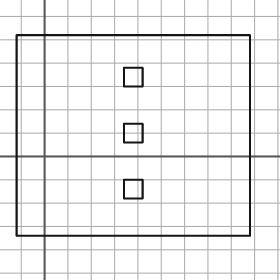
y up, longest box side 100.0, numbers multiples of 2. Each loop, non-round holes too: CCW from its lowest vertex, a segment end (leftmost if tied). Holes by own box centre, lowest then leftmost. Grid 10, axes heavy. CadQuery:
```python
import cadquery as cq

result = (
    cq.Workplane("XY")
    .moveTo(-12.0, -34.0)
    .lineTo(88.0, -34.0)
    .lineTo(88.0, 52.0)
    .lineTo(-12.0, 52.0)
    .close()
    .moveTo(34.0, -18.0)
    .lineTo(42.0, -18.0)
    .lineTo(42.0, -10.0)
    .lineTo(34.0, -10.0)
    .close()
    .moveTo(34.0, 6.0)
    .lineTo(42.0, 6.0)
    .lineTo(42.0, 14.0)
    .lineTo(34.0, 14.0)
    .close()
    .moveTo(34.0, 30.0)
    .lineTo(42.0, 30.0)
    .lineTo(42.0, 38.0)
    .lineTo(34.0, 38.0)
    .close()
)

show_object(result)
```